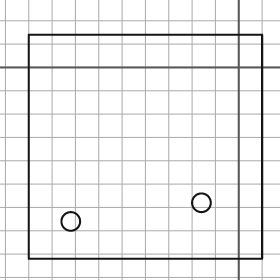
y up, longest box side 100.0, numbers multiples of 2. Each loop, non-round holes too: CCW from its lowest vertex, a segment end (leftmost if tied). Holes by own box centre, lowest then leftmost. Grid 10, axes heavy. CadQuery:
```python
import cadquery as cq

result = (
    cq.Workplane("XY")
    .moveTo(-90.0, -82.0)
    .lineTo(10.0, -82.0)
    .lineTo(10.0, 14.0)
    .lineTo(-90.0, 14.0)
    .close()
    .moveTo(-72.0, -66.0)
    .circle(4.0)
    .moveTo(-16.0, -58.0)
    .circle(4.0)
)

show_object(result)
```